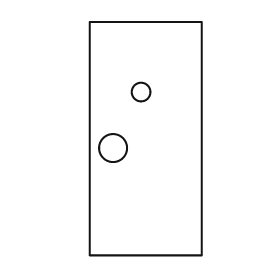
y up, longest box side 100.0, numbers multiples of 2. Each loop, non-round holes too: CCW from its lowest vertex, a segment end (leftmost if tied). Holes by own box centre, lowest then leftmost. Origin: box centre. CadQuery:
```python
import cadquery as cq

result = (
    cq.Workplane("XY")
    .moveTo(-24.0, -50.0)
    .lineTo(24.0, -50.0)
    .lineTo(24.0, 50.0)
    .lineTo(-24.0, 50.0)
    .close()
    .moveTo(-14.0, -4.0)
    .circle(6.0)
    .moveTo(-2.0, 20.0)
    .circle(4.0)
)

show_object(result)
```